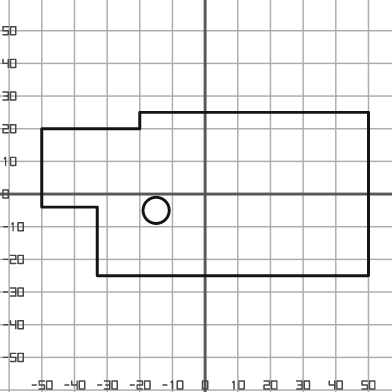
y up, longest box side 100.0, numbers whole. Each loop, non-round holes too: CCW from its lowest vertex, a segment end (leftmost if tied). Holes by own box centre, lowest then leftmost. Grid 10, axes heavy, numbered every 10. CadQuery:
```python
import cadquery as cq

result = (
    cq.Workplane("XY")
    .moveTo(-33.0, -25.0)
    .lineTo(50.0, -25.0)
    .lineTo(50.0, 25.0)
    .lineTo(-20.0, 25.0)
    .lineTo(-20.0, 20.0)
    .lineTo(-50.0, 20.0)
    .lineTo(-50.0, -4.0)
    .lineTo(-33.0, -4.0)
    .close()
    .moveTo(-15.0, -5.0)
    .circle(4.0)
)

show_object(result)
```